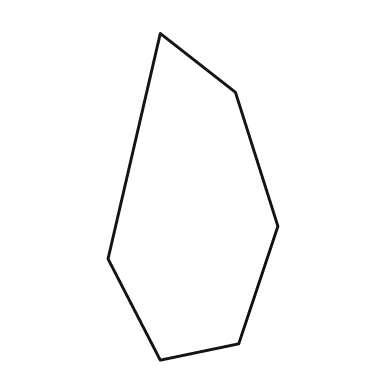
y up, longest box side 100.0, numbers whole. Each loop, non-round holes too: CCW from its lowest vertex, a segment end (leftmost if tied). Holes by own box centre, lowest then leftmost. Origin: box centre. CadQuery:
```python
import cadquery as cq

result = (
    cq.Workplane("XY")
    .moveTo(-10.0, -50.0)
    .lineTo(14.0, -45.0)
    .lineTo(26.0, -9.0)
    .lineTo(13.0, 32.0)
    .lineTo(-10.0, 50.0)
    .lineTo(-26.0, -19.0)
    .close()
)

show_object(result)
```